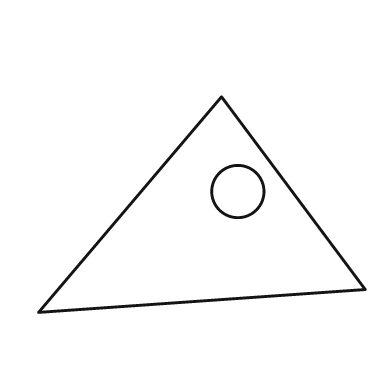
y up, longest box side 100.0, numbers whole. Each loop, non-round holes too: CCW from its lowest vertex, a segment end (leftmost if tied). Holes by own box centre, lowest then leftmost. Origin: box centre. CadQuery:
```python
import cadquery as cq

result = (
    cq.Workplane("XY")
    .moveTo(-50.0, -33.0)
    .lineTo(50.0, -26.0)
    .lineTo(6.0, 33.0)
    .close()
    .moveTo(11.0, 4.0)
    .circle(8.0)
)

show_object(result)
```